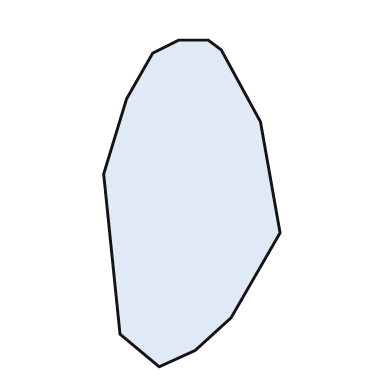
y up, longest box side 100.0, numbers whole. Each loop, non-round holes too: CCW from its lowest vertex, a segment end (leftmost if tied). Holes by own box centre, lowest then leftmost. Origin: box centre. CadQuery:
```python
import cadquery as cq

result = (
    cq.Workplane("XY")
    .moveTo(-10.0, -50.0)
    .lineTo(1.0, -45.0)
    .lineTo(12.0, -35.0)
    .lineTo(27.0, -9.0)
    .lineTo(21.0, 25.0)
    .lineTo(9.0, 47.0)
    .lineTo(5.0, 50.0)
    .lineTo(-4.0, 50.0)
    .lineTo(-12.0, 46.0)
    .lineTo(-20.0, 32.0)
    .lineTo(-27.0, 9.0)
    .lineTo(-22.0, -40.0)
    .close()
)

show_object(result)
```